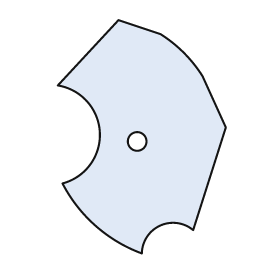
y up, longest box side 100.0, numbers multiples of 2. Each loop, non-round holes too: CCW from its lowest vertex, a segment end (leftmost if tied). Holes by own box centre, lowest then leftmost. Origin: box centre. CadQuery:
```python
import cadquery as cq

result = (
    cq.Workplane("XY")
    .moveTo(0.0, -50.0)
    .threePointArc((8.0, -38.0), (22.0, -40.0))
    .lineTo(36.0, 4.0)
    .lineTo(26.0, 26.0)
    .threePointArc((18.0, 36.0), (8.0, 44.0))
    .lineTo(-10.0, 50.0)
    .lineTo(-36.0, 22.0)
    .threePointArc((-18.0, 2.0), (-34.0, -20.0))
    .threePointArc((-20.0, -38.0), (0.0, -50.0))
    .close()
    .moveTo(-2.0, -2.0)
    .circle(4.0)
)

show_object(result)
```